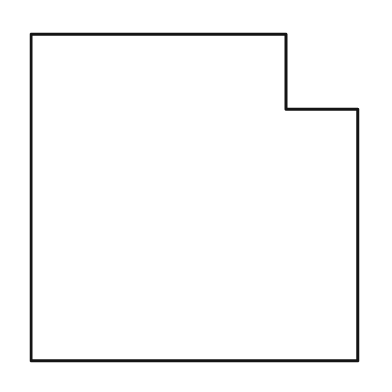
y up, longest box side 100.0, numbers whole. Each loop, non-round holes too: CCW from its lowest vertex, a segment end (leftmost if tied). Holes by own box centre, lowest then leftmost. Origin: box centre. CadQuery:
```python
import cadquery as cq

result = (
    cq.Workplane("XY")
    .moveTo(-50.0, -50.0)
    .lineTo(50.0, -50.0)
    .lineTo(50.0, 27.0)
    .lineTo(28.0, 27.0)
    .lineTo(28.0, 50.0)
    .lineTo(-50.0, 50.0)
    .close()
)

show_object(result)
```